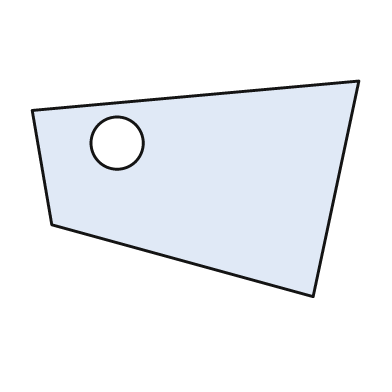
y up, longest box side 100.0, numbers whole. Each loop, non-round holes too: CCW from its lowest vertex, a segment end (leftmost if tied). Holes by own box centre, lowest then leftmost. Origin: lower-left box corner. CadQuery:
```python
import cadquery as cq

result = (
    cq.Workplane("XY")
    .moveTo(86.0, 0.0)
    .lineTo(100.0, 66.0)
    .lineTo(0.0, 57.0)
    .lineTo(6.0, 22.0)
    .close()
    .moveTo(26.0, 47.0)
    .circle(8.0)
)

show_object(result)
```